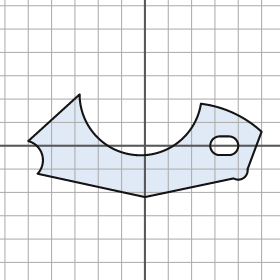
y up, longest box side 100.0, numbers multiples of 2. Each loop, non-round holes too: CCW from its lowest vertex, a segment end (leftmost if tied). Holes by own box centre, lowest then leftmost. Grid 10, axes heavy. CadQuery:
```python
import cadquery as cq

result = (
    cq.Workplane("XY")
    .moveTo(0.0, -22.0)
    .lineTo(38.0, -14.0)
    .threePointArc((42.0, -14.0), (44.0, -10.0))
    .lineTo(50.0, 6.0)
    .threePointArc((38.0, 14.0), (24.0, 18.0))
    .threePointArc((-4.0, -4.0), (-28.0, 22.0))
    .lineTo(-50.0, 2.0)
    .threePointArc((-44.0, -4.0), (-46.0, -12.0))
    .close()
    .moveTo(32.0, -4.0)
    .lineTo(36.0, -4.0)
    .threePointArc((40.0, 0.0), (36.0, 4.0))
    .lineTo(32.0, 4.0)
    .threePointArc((28.0, 0.0), (32.0, -4.0))
    .close()
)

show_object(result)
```